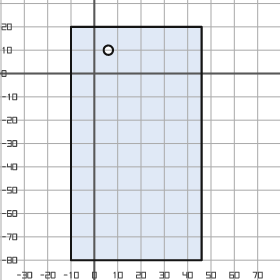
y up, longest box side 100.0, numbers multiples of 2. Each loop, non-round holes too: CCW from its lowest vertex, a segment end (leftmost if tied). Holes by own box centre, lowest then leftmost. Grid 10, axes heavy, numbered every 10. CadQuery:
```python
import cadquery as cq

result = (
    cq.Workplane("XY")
    .moveTo(-10.0, -80.0)
    .lineTo(46.0, -80.0)
    .lineTo(46.0, 20.0)
    .lineTo(-10.0, 20.0)
    .close()
    .moveTo(6.0, 10.0)
    .circle(2.0)
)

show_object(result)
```